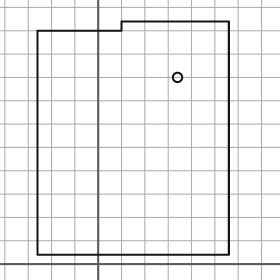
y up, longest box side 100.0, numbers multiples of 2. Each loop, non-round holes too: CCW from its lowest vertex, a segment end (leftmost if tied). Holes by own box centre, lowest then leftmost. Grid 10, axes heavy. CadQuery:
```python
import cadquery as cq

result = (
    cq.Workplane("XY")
    .moveTo(-26.0, 4.0)
    .lineTo(56.0, 4.0)
    .lineTo(56.0, 104.0)
    .lineTo(10.0, 104.0)
    .lineTo(10.0, 100.0)
    .lineTo(-26.0, 100.0)
    .close()
    .moveTo(34.0, 80.0)
    .circle(2.0)
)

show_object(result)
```